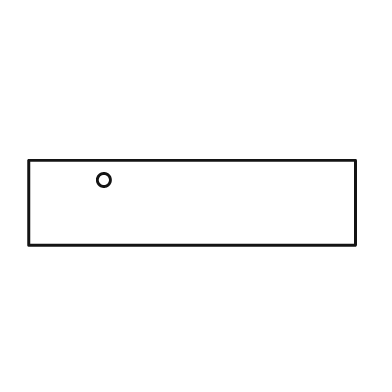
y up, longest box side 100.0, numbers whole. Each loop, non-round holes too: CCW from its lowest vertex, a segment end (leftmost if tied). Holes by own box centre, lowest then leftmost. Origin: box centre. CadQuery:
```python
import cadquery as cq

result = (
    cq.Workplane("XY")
    .moveTo(-50.0, -13.0)
    .lineTo(50.0, -13.0)
    .lineTo(50.0, 13.0)
    .lineTo(-50.0, 13.0)
    .close()
    .moveTo(-27.0, 7.0)
    .circle(2.0)
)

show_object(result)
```